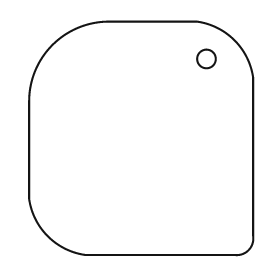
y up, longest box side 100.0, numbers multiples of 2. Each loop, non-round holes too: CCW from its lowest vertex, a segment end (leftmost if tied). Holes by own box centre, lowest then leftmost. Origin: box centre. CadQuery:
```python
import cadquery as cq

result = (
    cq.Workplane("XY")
    .moveTo(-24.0, -50.0)
    .lineTo(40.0, -50.0)
    .threePointArc((46.0, -48.0), (48.0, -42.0))
    .lineTo(48.0, 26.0)
    .threePointArc((40.0, 42.0), (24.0, 50.0))
    .lineTo(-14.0, 50.0)
    .threePointArc((-38.0, 40.0), (-48.0, 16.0))
    .lineTo(-48.0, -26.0)
    .threePointArc((-40.0, -42.0), (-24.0, -50.0))
    .close()
    .moveTo(28.0, 34.0)
    .circle(4.0)
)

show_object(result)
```